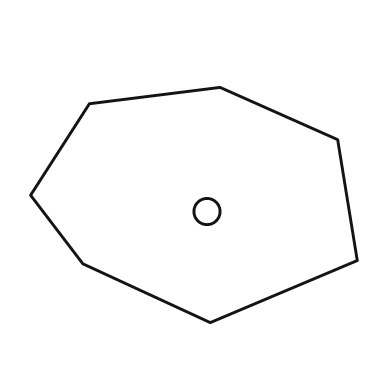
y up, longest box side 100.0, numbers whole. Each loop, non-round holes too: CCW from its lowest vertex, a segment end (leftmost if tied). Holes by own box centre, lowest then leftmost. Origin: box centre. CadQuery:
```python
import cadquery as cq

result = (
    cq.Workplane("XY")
    .moveTo(5.0, -36.0)
    .lineTo(50.0, -17.0)
    .lineTo(44.0, 20.0)
    .lineTo(8.0, 36.0)
    .lineTo(-32.0, 31.0)
    .lineTo(-50.0, 3.0)
    .lineTo(-34.0, -18.0)
    .close()
    .moveTo(4.0, -2.0)
    .circle(4.0)
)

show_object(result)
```